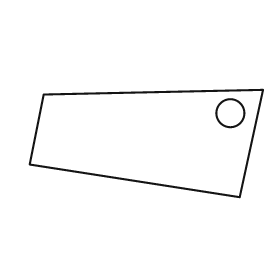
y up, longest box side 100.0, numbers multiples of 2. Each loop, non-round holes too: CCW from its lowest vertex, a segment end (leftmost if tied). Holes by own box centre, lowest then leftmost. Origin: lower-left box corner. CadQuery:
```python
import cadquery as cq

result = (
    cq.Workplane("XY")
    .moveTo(90.0, 0.0)
    .lineTo(100.0, 46.0)
    .lineTo(6.0, 44.0)
    .lineTo(0.0, 14.0)
    .close()
    .moveTo(86.0, 36.0)
    .circle(6.0)
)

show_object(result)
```